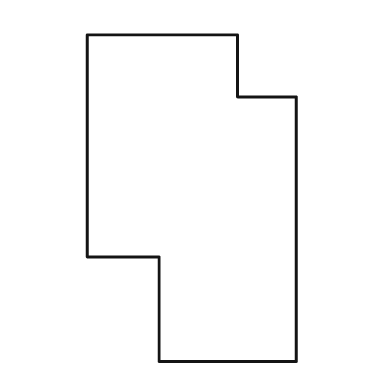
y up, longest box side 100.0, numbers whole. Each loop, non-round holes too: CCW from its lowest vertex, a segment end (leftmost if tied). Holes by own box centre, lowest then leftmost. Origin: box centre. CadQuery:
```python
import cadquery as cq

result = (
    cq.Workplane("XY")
    .moveTo(-10.0, -50.0)
    .lineTo(32.0, -50.0)
    .lineTo(32.0, 31.0)
    .lineTo(14.0, 31.0)
    .lineTo(14.0, 50.0)
    .lineTo(-32.0, 50.0)
    .lineTo(-32.0, -18.0)
    .lineTo(-10.0, -18.0)
    .close()
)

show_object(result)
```